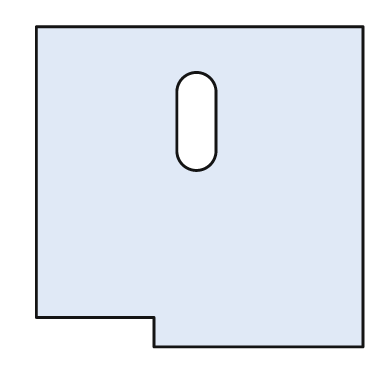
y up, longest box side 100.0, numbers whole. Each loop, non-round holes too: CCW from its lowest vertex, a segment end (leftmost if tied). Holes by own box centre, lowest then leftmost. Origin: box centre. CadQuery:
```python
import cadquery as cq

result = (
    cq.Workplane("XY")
    .moveTo(-14.0, -49.0)
    .lineTo(50.0, -49.0)
    .lineTo(50.0, 49.0)
    .lineTo(-50.0, 49.0)
    .lineTo(-50.0, -40.0)
    .lineTo(-14.0, -40.0)
    .close()
    .moveTo(-7.0, 11.0)
    .threePointArc((-1.0, 5.0), (5.0, 11.0))
    .lineTo(5.0, 29.0)
    .threePointArc((-1.0, 35.0), (-7.0, 29.0))
    .close()
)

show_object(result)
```